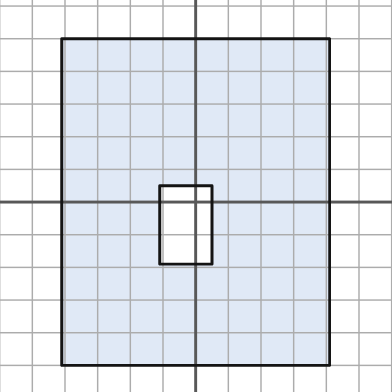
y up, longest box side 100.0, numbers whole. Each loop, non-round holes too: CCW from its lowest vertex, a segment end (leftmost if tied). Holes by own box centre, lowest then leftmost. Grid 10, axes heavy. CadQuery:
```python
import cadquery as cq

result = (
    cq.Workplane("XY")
    .moveTo(-41.0, -50.0)
    .lineTo(41.0, -50.0)
    .lineTo(41.0, 50.0)
    .lineTo(-41.0, 50.0)
    .close()
    .moveTo(-11.0, -19.0)
    .lineTo(5.0, -19.0)
    .lineTo(5.0, 5.0)
    .lineTo(-11.0, 5.0)
    .close()
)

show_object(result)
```